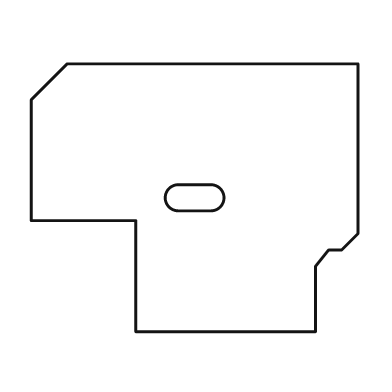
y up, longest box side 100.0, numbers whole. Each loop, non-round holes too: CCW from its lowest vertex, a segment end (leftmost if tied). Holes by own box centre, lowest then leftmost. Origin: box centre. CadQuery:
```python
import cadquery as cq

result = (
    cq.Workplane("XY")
    .moveTo(-18.0, -41.0)
    .lineTo(37.0, -41.0)
    .lineTo(37.0, -21.0)
    .lineTo(41.0, -16.0)
    .lineTo(45.0, -16.0)
    .lineTo(50.0, -11.0)
    .lineTo(50.0, 41.0)
    .lineTo(-39.0, 41.0)
    .lineTo(-50.0, 30.0)
    .lineTo(-50.0, -7.0)
    .lineTo(-18.0, -7.0)
    .close()
    .moveTo(-5.0, -4.0)
    .lineTo(5.0, -4.0)
    .threePointArc((9.0, 0.0), (5.0, 4.0))
    .lineTo(-5.0, 4.0)
    .threePointArc((-9.0, 0.0), (-5.0, -4.0))
    .close()
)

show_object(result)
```